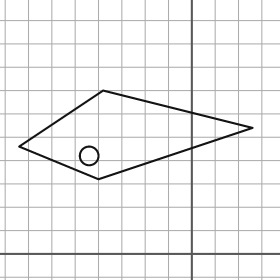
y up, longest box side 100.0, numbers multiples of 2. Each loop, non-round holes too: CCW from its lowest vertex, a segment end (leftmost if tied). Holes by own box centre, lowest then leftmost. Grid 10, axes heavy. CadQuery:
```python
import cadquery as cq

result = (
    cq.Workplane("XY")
    .moveTo(-40.0, 32.0)
    .lineTo(26.0, 54.0)
    .lineTo(-38.0, 70.0)
    .lineTo(-74.0, 46.0)
    .close()
    .moveTo(-44.0, 42.0)
    .circle(4.0)
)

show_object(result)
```